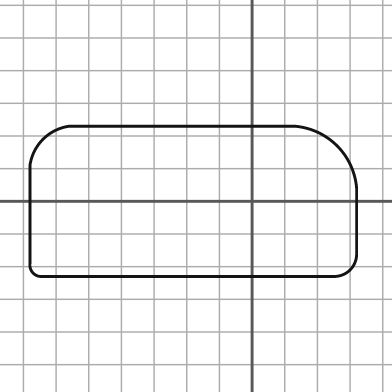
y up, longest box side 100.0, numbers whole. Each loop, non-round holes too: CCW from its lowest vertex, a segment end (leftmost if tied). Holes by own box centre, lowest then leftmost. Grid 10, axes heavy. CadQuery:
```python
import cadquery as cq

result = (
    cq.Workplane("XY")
    .moveTo(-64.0, -23.0)
    .lineTo(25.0, -23.0)
    .threePointArc((30.0, -21.0), (32.0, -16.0))
    .lineTo(32.0, 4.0)
    .threePointArc((26.0, 17.0), (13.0, 23.0))
    .lineTo(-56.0, 23.0)
    .threePointArc((-64.0, 19.0), (-68.0, 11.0))
    .lineTo(-68.0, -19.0)
    .threePointArc((-67.0, -22.0), (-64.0, -23.0))
    .close()
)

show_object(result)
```